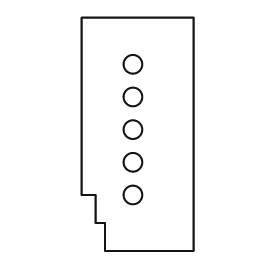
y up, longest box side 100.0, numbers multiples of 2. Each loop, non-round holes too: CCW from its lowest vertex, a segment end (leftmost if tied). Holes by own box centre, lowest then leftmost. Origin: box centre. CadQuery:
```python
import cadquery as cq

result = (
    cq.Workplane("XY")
    .moveTo(-14.0, -50.0)
    .lineTo(24.0, -50.0)
    .lineTo(24.0, 50.0)
    .lineTo(-24.0, 50.0)
    .lineTo(-24.0, -26.0)
    .lineTo(-18.0, -26.0)
    .lineTo(-18.0, -38.0)
    .lineTo(-14.0, -38.0)
    .close()
    .moveTo(-2.0, -26.0)
    .circle(4.0)
    .moveTo(-2.0, -12.0)
    .circle(4.0)
    .moveTo(-2.0, 2.0)
    .circle(4.0)
    .moveTo(-2.0, 16.0)
    .circle(4.0)
    .moveTo(-2.0, 30.0)
    .circle(4.0)
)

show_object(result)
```